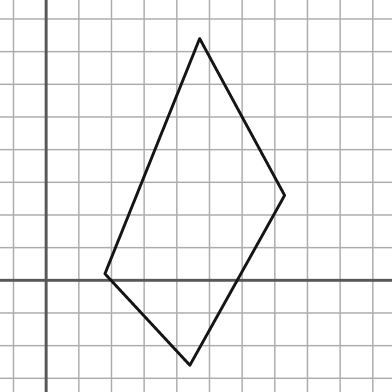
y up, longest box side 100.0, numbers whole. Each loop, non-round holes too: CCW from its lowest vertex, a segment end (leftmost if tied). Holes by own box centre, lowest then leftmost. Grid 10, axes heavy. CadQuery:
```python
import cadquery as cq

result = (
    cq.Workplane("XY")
    .moveTo(44.0, -26.0)
    .lineTo(73.0, 26.0)
    .lineTo(47.0, 74.0)
    .lineTo(18.0, 2.0)
    .close()
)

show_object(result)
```